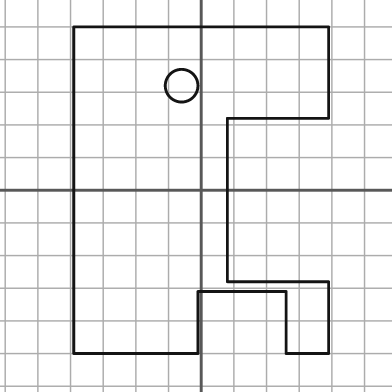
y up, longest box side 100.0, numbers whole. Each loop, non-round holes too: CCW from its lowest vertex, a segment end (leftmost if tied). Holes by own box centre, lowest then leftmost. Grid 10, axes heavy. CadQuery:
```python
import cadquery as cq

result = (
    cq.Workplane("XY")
    .moveTo(-39.0, -50.0)
    .lineTo(-1.0, -50.0)
    .lineTo(-1.0, -31.0)
    .lineTo(26.0, -31.0)
    .lineTo(26.0, -50.0)
    .lineTo(39.0, -50.0)
    .lineTo(39.0, -28.0)
    .lineTo(8.0, -28.0)
    .lineTo(8.0, 22.0)
    .lineTo(39.0, 22.0)
    .lineTo(39.0, 50.0)
    .lineTo(-39.0, 50.0)
    .close()
    .moveTo(-6.0, 32.0)
    .circle(5.0)
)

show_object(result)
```